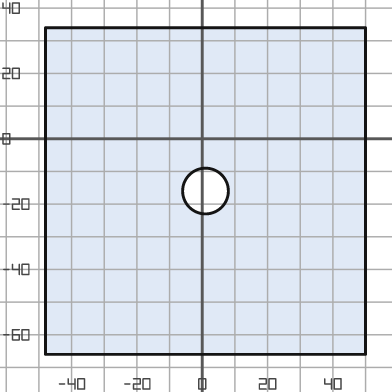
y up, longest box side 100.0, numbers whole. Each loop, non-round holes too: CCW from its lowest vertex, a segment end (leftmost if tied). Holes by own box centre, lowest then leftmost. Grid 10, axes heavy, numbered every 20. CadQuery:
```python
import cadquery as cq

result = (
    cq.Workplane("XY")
    .moveTo(-48.0, -66.0)
    .lineTo(50.0, -66.0)
    .lineTo(50.0, 34.0)
    .lineTo(-48.0, 34.0)
    .close()
    .moveTo(1.0, -16.0)
    .circle(7.0)
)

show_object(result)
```